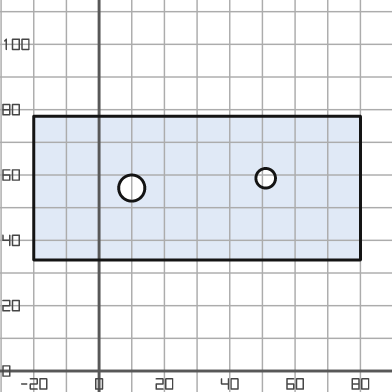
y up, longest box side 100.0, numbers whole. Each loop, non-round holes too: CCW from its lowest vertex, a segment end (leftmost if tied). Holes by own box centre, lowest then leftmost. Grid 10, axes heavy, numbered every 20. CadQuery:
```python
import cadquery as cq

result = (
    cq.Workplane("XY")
    .moveTo(-20.0, 34.0)
    .lineTo(80.0, 34.0)
    .lineTo(80.0, 78.0)
    .lineTo(-20.0, 78.0)
    .close()
    .moveTo(10.0, 56.0)
    .circle(4.0)
    .moveTo(51.0, 59.0)
    .circle(3.0)
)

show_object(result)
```